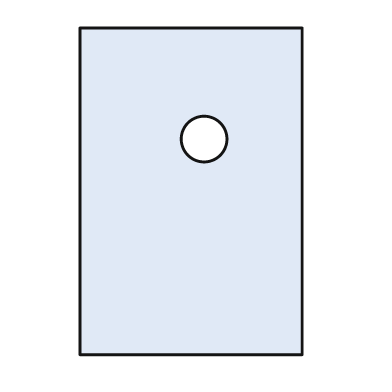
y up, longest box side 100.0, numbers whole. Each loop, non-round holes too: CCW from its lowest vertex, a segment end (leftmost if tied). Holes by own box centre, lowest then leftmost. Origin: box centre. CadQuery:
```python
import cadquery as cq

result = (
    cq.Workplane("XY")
    .moveTo(-34.0, -50.0)
    .lineTo(34.0, -50.0)
    .lineTo(34.0, 50.0)
    .lineTo(-34.0, 50.0)
    .close()
    .moveTo(4.0, 16.0)
    .circle(7.0)
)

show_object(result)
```